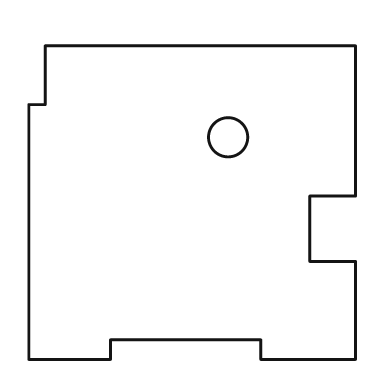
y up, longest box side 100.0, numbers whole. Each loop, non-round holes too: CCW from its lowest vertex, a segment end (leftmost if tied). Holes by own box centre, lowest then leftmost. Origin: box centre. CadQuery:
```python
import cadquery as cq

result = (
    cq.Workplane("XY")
    .moveTo(-50.0, -48.0)
    .lineTo(-25.0, -48.0)
    .lineTo(-25.0, -42.0)
    .lineTo(21.0, -42.0)
    .lineTo(21.0, -48.0)
    .lineTo(50.0, -48.0)
    .lineTo(50.0, -18.0)
    .lineTo(36.0, -18.0)
    .lineTo(36.0, 2.0)
    .lineTo(50.0, 2.0)
    .lineTo(50.0, 48.0)
    .lineTo(-45.0, 48.0)
    .lineTo(-45.0, 30.0)
    .lineTo(-50.0, 30.0)
    .close()
    .moveTo(11.0, 20.0)
    .circle(6.0)
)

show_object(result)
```